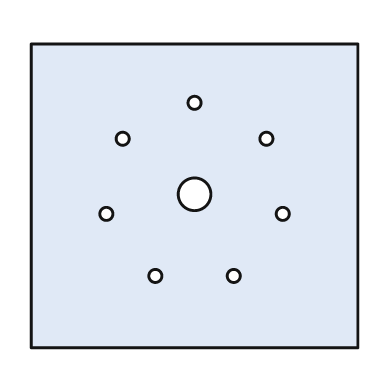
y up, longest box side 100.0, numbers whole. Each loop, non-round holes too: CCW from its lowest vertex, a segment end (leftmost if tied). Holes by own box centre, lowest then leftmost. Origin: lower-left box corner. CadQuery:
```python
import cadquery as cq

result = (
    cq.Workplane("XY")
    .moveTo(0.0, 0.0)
    .lineTo(100.0, 0.0)
    .lineTo(100.0, 93.0)
    .lineTo(0.0, 93.0)
    .close()
    .moveTo(38.0, 22.0)
    .circle(2.0)
    .moveTo(62.0, 22.0)
    .circle(2.0)
    .moveTo(23.0, 41.0)
    .circle(2.0)
    .moveTo(77.0, 41.0)
    .circle(2.0)
    .moveTo(50.0, 47.0)
    .circle(5.0)
    .moveTo(28.0, 64.0)
    .circle(2.0)
    .moveTo(72.0, 64.0)
    .circle(2.0)
    .moveTo(50.0, 75.0)
    .circle(2.0)
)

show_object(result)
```